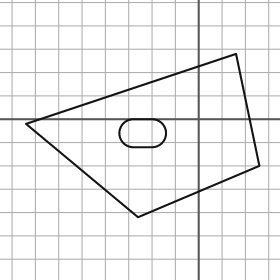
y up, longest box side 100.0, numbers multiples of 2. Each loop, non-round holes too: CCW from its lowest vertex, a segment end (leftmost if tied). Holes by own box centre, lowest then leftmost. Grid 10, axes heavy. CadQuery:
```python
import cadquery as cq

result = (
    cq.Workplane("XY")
    .moveTo(-26.0, -42.0)
    .lineTo(26.0, -20.0)
    .lineTo(16.0, 28.0)
    .lineTo(-74.0, -2.0)
    .close()
    .moveTo(-28.0, -12.0)
    .lineTo(-20.0, -12.0)
    .threePointArc((-14.0, -6.0), (-20.0, 0.0))
    .lineTo(-28.0, 0.0)
    .threePointArc((-34.0, -6.0), (-28.0, -12.0))
    .close()
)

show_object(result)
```